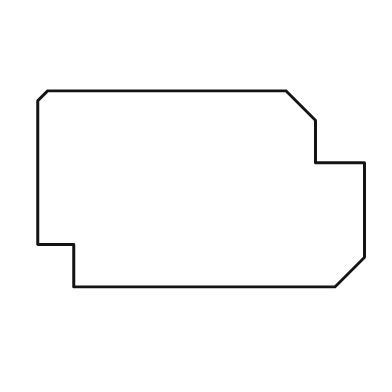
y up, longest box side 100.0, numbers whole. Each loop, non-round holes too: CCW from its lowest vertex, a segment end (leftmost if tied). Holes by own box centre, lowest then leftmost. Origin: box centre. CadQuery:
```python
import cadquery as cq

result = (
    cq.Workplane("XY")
    .moveTo(-39.0, -30.0)
    .lineTo(41.0, -30.0)
    .lineTo(50.0, -21.0)
    .lineTo(50.0, 8.0)
    .lineTo(35.0, 8.0)
    .lineTo(35.0, 21.0)
    .lineTo(26.0, 30.0)
    .lineTo(-47.0, 30.0)
    .lineTo(-50.0, 27.0)
    .lineTo(-50.0, -17.0)
    .lineTo(-39.0, -17.0)
    .close()
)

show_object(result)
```